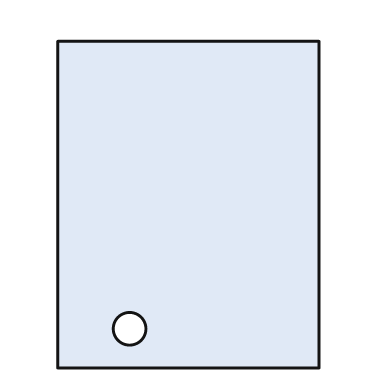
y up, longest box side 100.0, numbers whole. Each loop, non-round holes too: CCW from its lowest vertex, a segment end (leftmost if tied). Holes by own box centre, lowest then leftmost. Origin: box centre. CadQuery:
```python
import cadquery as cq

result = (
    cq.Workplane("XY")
    .moveTo(-40.0, -50.0)
    .lineTo(40.0, -50.0)
    .lineTo(40.0, 50.0)
    .lineTo(-40.0, 50.0)
    .close()
    .moveTo(-18.0, -38.0)
    .circle(5.0)
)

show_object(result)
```